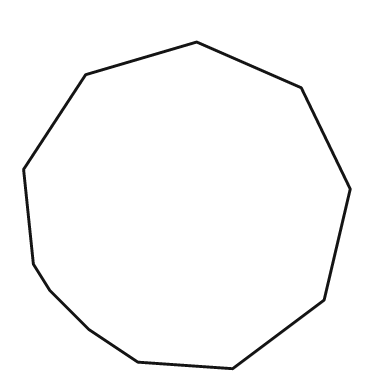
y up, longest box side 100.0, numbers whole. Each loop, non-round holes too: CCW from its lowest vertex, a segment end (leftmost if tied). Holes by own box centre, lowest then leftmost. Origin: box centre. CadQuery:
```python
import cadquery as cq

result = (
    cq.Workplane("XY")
    .moveTo(14.0, -50.0)
    .lineTo(42.0, -29.0)
    .lineTo(50.0, 5.0)
    .lineTo(35.0, 36.0)
    .lineTo(3.0, 50.0)
    .lineTo(-31.0, 40.0)
    .lineTo(-50.0, 11.0)
    .lineTo(-47.0, -18.0)
    .lineTo(-42.0, -26.0)
    .lineTo(-30.0, -38.0)
    .lineTo(-15.0, -48.0)
    .close()
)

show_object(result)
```